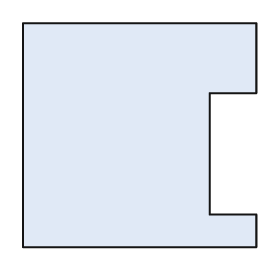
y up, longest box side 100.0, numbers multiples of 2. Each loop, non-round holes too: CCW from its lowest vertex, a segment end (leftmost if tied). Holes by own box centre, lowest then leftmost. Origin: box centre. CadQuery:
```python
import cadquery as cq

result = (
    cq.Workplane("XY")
    .moveTo(-50.0, -48.0)
    .lineTo(50.0, -48.0)
    .lineTo(50.0, -34.0)
    .lineTo(30.0, -34.0)
    .lineTo(30.0, 18.0)
    .lineTo(50.0, 18.0)
    .lineTo(50.0, 48.0)
    .lineTo(-50.0, 48.0)
    .close()
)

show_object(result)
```